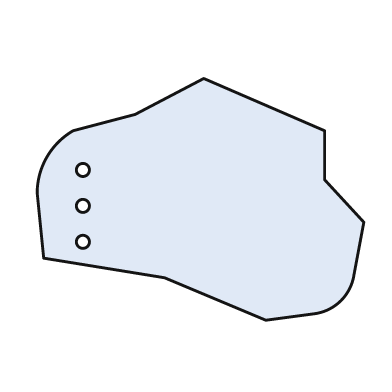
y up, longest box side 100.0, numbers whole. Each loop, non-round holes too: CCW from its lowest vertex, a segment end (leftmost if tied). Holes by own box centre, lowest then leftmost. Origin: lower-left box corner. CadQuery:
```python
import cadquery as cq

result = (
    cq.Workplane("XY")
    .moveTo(70.0, 0.0)
    .lineTo(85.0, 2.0)
    .threePointArc((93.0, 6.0), (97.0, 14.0))
    .lineTo(100.0, 30.0)
    .lineTo(88.0, 43.0)
    .lineTo(88.0, 58.0)
    .lineTo(51.0, 74.0)
    .lineTo(30.0, 63.0)
    .lineTo(11.0, 58.0)
    .threePointArc((3.0, 50.0), (0.0, 39.0))
    .lineTo(2.0, 19.0)
    .lineTo(39.0, 13.0)
    .close()
    .moveTo(14.0, 24.0)
    .circle(2.0)
    .moveTo(14.0, 35.0)
    .circle(2.0)
    .moveTo(14.0, 46.0)
    .circle(2.0)
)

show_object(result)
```